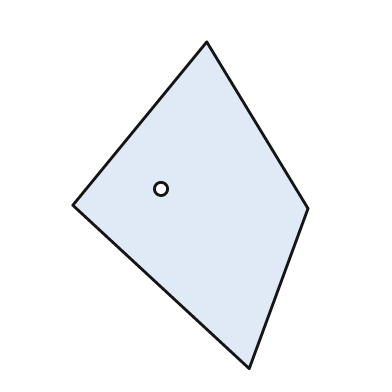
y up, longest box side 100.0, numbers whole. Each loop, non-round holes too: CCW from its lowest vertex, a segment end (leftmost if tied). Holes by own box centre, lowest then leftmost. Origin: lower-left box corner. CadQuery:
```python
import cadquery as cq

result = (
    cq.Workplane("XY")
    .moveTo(54.0, 0.0)
    .lineTo(72.0, 49.0)
    .lineTo(41.0, 100.0)
    .lineTo(0.0, 50.0)
    .close()
    .moveTo(27.0, 55.0)
    .circle(2.0)
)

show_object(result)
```